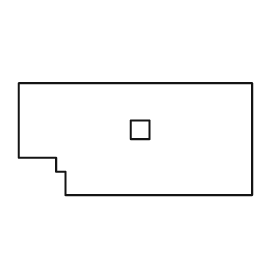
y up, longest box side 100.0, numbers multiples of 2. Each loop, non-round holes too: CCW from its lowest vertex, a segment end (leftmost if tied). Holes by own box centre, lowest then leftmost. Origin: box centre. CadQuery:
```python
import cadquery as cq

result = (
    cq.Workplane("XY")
    .moveTo(-30.0, -24.0)
    .lineTo(50.0, -24.0)
    .lineTo(50.0, 24.0)
    .lineTo(-50.0, 24.0)
    .lineTo(-50.0, -8.0)
    .lineTo(-34.0, -8.0)
    .lineTo(-34.0, -14.0)
    .lineTo(-30.0, -14.0)
    .close()
    .moveTo(-2.0, 0.0)
    .lineTo(6.0, 0.0)
    .lineTo(6.0, 8.0)
    .lineTo(-2.0, 8.0)
    .close()
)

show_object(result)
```